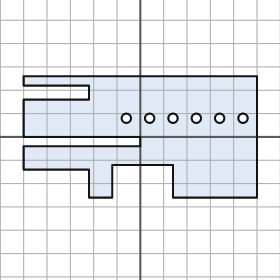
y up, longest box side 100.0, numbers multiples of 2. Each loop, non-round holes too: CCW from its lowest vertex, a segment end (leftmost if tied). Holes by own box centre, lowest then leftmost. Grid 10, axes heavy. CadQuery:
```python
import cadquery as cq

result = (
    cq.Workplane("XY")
    .moveTo(-22.0, -26.0)
    .lineTo(-12.0, -26.0)
    .lineTo(-12.0, -12.0)
    .lineTo(14.0, -12.0)
    .lineTo(14.0, -26.0)
    .lineTo(50.0, -26.0)
    .lineTo(50.0, 26.0)
    .lineTo(-50.0, 26.0)
    .lineTo(-50.0, 22.0)
    .lineTo(-22.0, 22.0)
    .lineTo(-22.0, 16.0)
    .lineTo(-50.0, 16.0)
    .lineTo(-50.0, 0.0)
    .lineTo(0.0, 0.0)
    .lineTo(0.0, -4.0)
    .lineTo(-50.0, -4.0)
    .lineTo(-50.0, -14.0)
    .lineTo(-22.0, -14.0)
    .close()
    .moveTo(-6.0, 8.0)
    .circle(2.0)
    .moveTo(4.0, 8.0)
    .circle(2.0)
    .moveTo(14.0, 8.0)
    .circle(2.0)
    .moveTo(24.0, 8.0)
    .circle(2.0)
    .moveTo(34.0, 8.0)
    .circle(2.0)
    .moveTo(44.0, 8.0)
    .circle(2.0)
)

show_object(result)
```